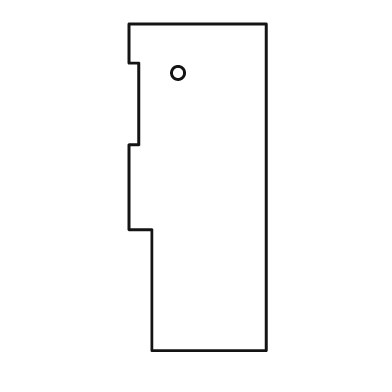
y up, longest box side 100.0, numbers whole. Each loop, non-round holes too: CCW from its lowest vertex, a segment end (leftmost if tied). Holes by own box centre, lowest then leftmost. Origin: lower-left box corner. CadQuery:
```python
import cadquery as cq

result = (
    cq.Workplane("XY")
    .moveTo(7.0, 0.0)
    .lineTo(42.0, 0.0)
    .lineTo(42.0, 100.0)
    .lineTo(0.0, 100.0)
    .lineTo(0.0, 88.0)
    .lineTo(3.0, 88.0)
    .lineTo(3.0, 63.0)
    .lineTo(0.0, 63.0)
    .lineTo(0.0, 37.0)
    .lineTo(7.0, 37.0)
    .close()
    .moveTo(15.0, 85.0)
    .circle(2.0)
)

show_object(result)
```